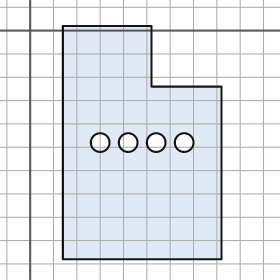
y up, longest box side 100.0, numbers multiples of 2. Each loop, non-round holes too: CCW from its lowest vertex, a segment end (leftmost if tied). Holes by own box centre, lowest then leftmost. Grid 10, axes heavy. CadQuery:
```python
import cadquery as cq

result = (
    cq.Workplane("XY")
    .moveTo(14.0, -98.0)
    .lineTo(82.0, -98.0)
    .lineTo(82.0, -24.0)
    .lineTo(52.0, -24.0)
    .lineTo(52.0, 2.0)
    .lineTo(14.0, 2.0)
    .close()
    .moveTo(30.0, -48.0)
    .circle(4.0)
    .moveTo(42.0, -48.0)
    .circle(4.0)
    .moveTo(54.0, -48.0)
    .circle(4.0)
    .moveTo(66.0, -48.0)
    .circle(4.0)
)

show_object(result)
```